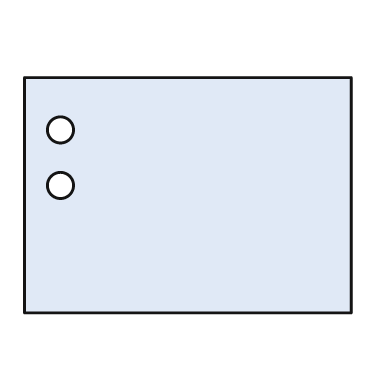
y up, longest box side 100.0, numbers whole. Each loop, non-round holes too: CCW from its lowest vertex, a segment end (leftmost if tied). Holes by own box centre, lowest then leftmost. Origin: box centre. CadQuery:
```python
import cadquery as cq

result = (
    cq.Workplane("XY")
    .moveTo(-50.0, -36.0)
    .lineTo(50.0, -36.0)
    .lineTo(50.0, 36.0)
    .lineTo(-50.0, 36.0)
    .close()
    .moveTo(-39.0, 3.0)
    .circle(4.0)
    .moveTo(-39.0, 20.0)
    .circle(4.0)
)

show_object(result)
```